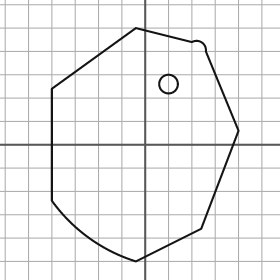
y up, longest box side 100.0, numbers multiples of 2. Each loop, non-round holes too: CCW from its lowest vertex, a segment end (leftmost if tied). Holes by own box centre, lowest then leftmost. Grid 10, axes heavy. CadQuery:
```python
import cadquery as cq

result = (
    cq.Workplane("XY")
    .moveTo(-4.0, -50.0)
    .lineTo(24.0, -36.0)
    .lineTo(40.0, 6.0)
    .lineTo(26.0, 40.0)
    .threePointArc((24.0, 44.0), (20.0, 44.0))
    .lineTo(-4.0, 50.0)
    .lineTo(-40.0, 24.0)
    .lineTo(-40.0, -24.0)
    .threePointArc((-24.0, -40.0), (-4.0, -50.0))
    .close()
    .moveTo(10.0, 26.0)
    .circle(4.0)
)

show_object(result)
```